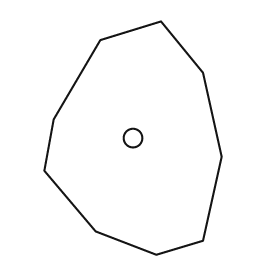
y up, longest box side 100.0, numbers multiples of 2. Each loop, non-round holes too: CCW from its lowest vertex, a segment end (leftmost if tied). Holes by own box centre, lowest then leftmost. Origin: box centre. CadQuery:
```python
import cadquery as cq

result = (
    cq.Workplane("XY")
    .moveTo(10.0, -50.0)
    .lineTo(30.0, -44.0)
    .lineTo(38.0, -8.0)
    .lineTo(30.0, 28.0)
    .lineTo(12.0, 50.0)
    .lineTo(-14.0, 42.0)
    .lineTo(-34.0, 8.0)
    .lineTo(-38.0, -14.0)
    .lineTo(-16.0, -40.0)
    .close()
    .moveTo(0.0, 0.0)
    .circle(4.0)
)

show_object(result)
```